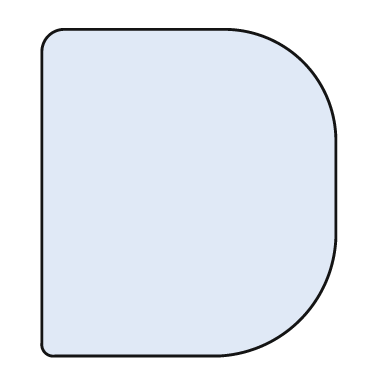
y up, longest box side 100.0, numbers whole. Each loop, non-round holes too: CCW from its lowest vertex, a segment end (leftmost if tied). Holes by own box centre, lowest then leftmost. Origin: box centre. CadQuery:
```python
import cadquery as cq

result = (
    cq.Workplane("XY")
    .moveTo(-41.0, -50.0)
    .lineTo(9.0, -50.0)
    .threePointArc((34.0, -39.0), (45.0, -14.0))
    .lineTo(45.0, 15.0)
    .threePointArc((35.0, 40.0), (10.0, 50.0))
    .lineTo(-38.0, 50.0)
    .threePointArc((-43.0, 48.0), (-45.0, 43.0))
    .lineTo(-45.0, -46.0)
    .threePointArc((-44.0, -49.0), (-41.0, -50.0))
    .close()
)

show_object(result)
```